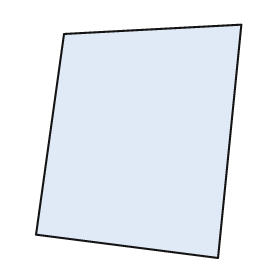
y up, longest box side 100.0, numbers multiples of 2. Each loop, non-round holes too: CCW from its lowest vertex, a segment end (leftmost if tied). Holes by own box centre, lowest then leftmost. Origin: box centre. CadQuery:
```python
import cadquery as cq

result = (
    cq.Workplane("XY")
    .moveTo(34.0, -50.0)
    .lineTo(44.0, 50.0)
    .lineTo(-32.0, 46.0)
    .lineTo(-44.0, -40.0)
    .close()
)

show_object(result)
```